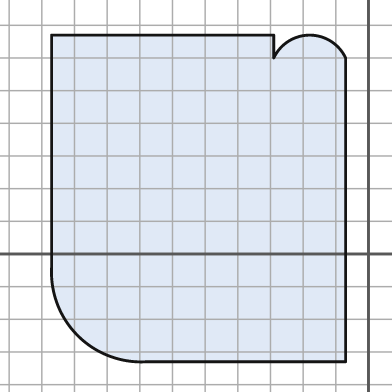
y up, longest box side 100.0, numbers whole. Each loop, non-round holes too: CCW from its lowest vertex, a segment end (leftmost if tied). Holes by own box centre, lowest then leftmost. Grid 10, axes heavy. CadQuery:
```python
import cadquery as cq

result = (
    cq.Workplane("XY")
    .moveTo(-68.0, -33.0)
    .lineTo(-7.0, -33.0)
    .lineTo(-7.0, 60.0)
    .threePointArc((-18.0, 67.0), (-29.0, 60.0))
    .lineTo(-29.0, 67.0)
    .lineTo(-97.0, 67.0)
    .lineTo(-97.0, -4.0)
    .threePointArc((-89.0, -25.0), (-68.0, -33.0))
    .close()
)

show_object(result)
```